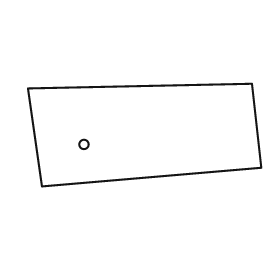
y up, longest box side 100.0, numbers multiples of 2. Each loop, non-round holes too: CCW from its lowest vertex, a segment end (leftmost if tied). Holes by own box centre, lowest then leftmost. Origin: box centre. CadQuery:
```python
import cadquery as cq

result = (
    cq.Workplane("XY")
    .moveTo(-44.0, -22.0)
    .lineTo(50.0, -14.0)
    .lineTo(46.0, 22.0)
    .lineTo(-50.0, 20.0)
    .close()
    .moveTo(-26.0, -4.0)
    .circle(2.0)
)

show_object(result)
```